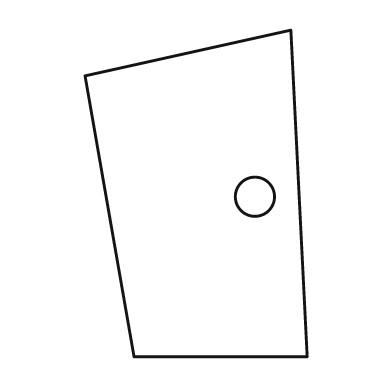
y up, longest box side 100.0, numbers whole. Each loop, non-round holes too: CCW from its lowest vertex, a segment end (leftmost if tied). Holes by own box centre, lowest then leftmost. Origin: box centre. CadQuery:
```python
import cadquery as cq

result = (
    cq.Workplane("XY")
    .moveTo(-19.0, -50.0)
    .lineTo(34.0, -50.0)
    .lineTo(29.0, 50.0)
    .lineTo(-34.0, 36.0)
    .close()
    .moveTo(18.0, -1.0)
    .circle(6.0)
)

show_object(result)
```